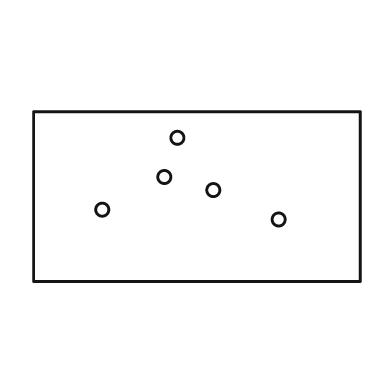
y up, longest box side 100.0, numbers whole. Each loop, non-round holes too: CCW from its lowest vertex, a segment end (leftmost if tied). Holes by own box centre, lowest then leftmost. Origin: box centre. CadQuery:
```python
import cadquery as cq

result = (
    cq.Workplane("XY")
    .moveTo(-50.0, -26.0)
    .lineTo(50.0, -26.0)
    .lineTo(50.0, 26.0)
    .lineTo(-50.0, 26.0)
    .close()
    .moveTo(25.0, -7.0)
    .circle(2.0)
    .moveTo(-29.0, -4.0)
    .circle(2.0)
    .moveTo(5.0, 2.0)
    .circle(2.0)
    .moveTo(-10.0, 6.0)
    .circle(2.0)
    .moveTo(-6.0, 18.0)
    .circle(2.0)
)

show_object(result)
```